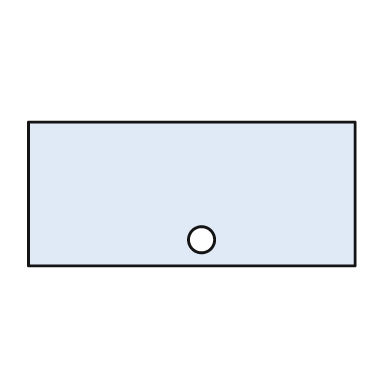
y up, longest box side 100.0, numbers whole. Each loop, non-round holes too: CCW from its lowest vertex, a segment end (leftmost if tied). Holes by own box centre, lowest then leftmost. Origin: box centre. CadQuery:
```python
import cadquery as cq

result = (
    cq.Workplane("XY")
    .moveTo(-50.0, -22.0)
    .lineTo(50.0, -22.0)
    .lineTo(50.0, 22.0)
    .lineTo(-50.0, 22.0)
    .close()
    .moveTo(3.0, -14.0)
    .circle(4.0)
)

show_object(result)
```